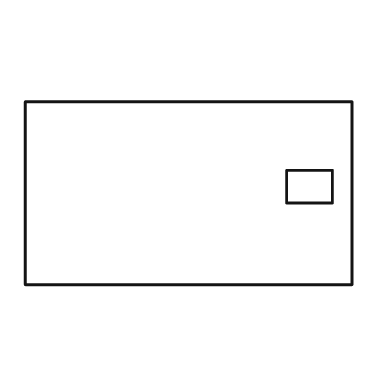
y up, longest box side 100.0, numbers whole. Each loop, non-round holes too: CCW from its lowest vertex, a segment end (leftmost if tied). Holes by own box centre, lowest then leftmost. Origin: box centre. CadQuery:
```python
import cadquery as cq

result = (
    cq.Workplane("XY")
    .moveTo(-50.0, -28.0)
    .lineTo(50.0, -28.0)
    .lineTo(50.0, 28.0)
    .lineTo(-50.0, 28.0)
    .close()
    .moveTo(30.0, -3.0)
    .lineTo(44.0, -3.0)
    .lineTo(44.0, 7.0)
    .lineTo(30.0, 7.0)
    .close()
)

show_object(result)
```